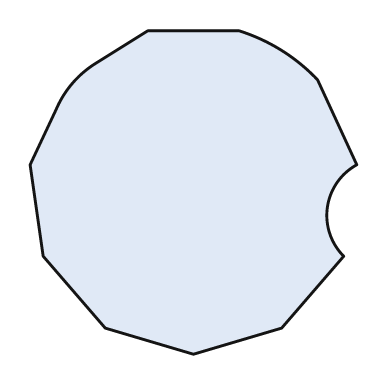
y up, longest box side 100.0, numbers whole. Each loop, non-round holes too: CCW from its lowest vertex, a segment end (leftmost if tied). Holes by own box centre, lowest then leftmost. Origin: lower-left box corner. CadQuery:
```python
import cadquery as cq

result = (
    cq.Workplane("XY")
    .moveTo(50.0, 0.0)
    .lineTo(77.0, 8.0)
    .lineTo(96.0, 30.0)
    .threePointArc((91.0, 45.0), (100.0, 58.0))
    .lineTo(88.0, 84.0)
    .threePointArc((77.0, 93.0), (64.0, 99.0))
    .lineTo(36.0, 99.0)
    .lineTo(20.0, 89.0)
    .threePointArc((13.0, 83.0), (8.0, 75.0))
    .lineTo(0.0, 58.0)
    .lineTo(4.0, 30.0)
    .lineTo(23.0, 8.0)
    .close()
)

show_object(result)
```